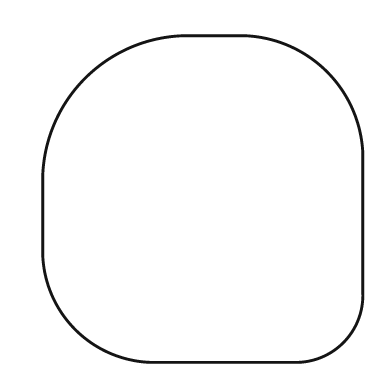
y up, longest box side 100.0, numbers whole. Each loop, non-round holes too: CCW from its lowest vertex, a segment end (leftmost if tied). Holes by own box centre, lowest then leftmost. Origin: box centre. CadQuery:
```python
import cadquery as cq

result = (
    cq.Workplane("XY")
    .moveTo(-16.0, -50.0)
    .lineTo(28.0, -50.0)
    .threePointArc((43.0, -44.0), (49.0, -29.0))
    .lineTo(49.0, 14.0)
    .threePointArc((38.0, 39.0), (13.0, 50.0))
    .lineTo(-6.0, 50.0)
    .threePointArc((-36.0, 37.0), (-49.0, 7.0))
    .lineTo(-49.0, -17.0)
    .threePointArc((-39.0, -40.0), (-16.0, -50.0))
    .close()
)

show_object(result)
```